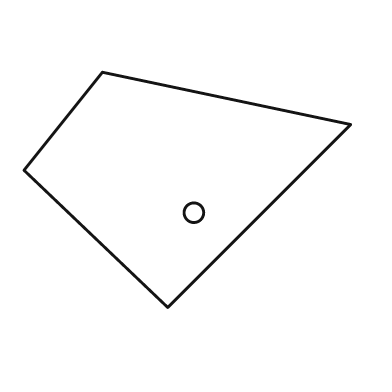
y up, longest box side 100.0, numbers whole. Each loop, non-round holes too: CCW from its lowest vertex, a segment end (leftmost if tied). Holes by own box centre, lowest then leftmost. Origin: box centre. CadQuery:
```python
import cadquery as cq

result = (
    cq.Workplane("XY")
    .moveTo(-6.0, -36.0)
    .lineTo(50.0, 20.0)
    .lineTo(-26.0, 36.0)
    .lineTo(-50.0, 6.0)
    .close()
    .moveTo(2.0, -7.0)
    .circle(3.0)
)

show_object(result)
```